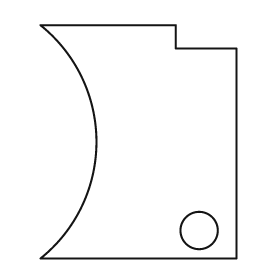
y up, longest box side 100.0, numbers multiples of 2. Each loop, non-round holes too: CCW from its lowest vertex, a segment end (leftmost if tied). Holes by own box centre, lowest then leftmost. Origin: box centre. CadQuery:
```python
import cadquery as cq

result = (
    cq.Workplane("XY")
    .moveTo(-42.0, -50.0)
    .lineTo(42.0, -50.0)
    .lineTo(42.0, 40.0)
    .lineTo(16.0, 40.0)
    .lineTo(16.0, 50.0)
    .lineTo(-42.0, 50.0)
    .threePointArc((-18.0, 0.0), (-42.0, -50.0))
    .close()
    .moveTo(26.0, -38.0)
    .circle(8.0)
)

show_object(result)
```